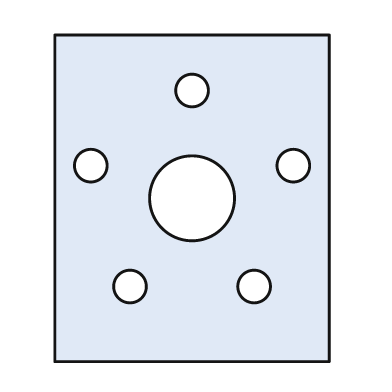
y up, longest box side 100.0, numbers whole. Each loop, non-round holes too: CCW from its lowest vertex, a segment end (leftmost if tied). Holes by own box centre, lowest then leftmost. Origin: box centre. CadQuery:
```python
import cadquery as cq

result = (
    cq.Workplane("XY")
    .moveTo(-42.0, -50.0)
    .lineTo(42.0, -50.0)
    .lineTo(42.0, 50.0)
    .lineTo(-42.0, 50.0)
    .close()
    .moveTo(-19.0, -27.0)
    .circle(5.0)
    .moveTo(19.0, -27.0)
    .circle(5.0)
    .moveTo(0.0, 0.0)
    .circle(13.0)
    .moveTo(-31.0, 10.0)
    .circle(5.0)
    .moveTo(31.0, 10.0)
    .circle(5.0)
    .moveTo(0.0, 33.0)
    .circle(5.0)
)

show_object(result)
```